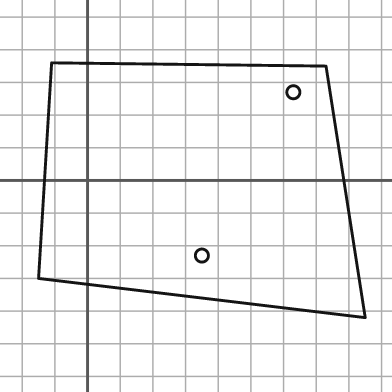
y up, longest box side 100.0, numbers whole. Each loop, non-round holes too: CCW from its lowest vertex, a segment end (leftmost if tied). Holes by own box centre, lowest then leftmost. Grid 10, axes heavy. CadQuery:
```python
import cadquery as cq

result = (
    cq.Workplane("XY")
    .moveTo(85.0, -42.0)
    .lineTo(73.0, 35.0)
    .lineTo(-11.0, 36.0)
    .lineTo(-15.0, -30.0)
    .close()
    .moveTo(35.0, -23.0)
    .circle(2.0)
    .moveTo(63.0, 27.0)
    .circle(2.0)
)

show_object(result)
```